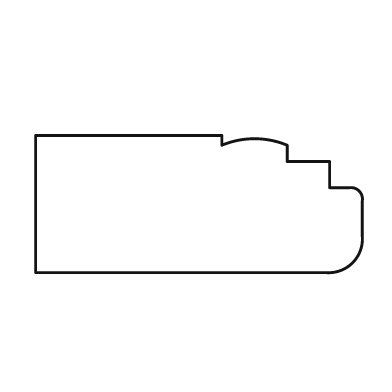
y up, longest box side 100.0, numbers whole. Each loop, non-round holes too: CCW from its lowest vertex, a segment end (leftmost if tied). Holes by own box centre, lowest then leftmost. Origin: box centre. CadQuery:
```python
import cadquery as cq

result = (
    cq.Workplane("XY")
    .moveTo(-50.0, -21.0)
    .lineTo(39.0, -21.0)
    .threePointArc((47.0, -18.0), (50.0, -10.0))
    .lineTo(50.0, 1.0)
    .threePointArc((49.0, 4.0), (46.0, 5.0))
    .lineTo(40.0, 5.0)
    .lineTo(40.0, 13.0)
    .lineTo(27.0, 13.0)
    .lineTo(27.0, 18.0)
    .threePointArc((17.0, 20.0), (7.0, 18.0))
    .lineTo(7.0, 21.0)
    .lineTo(-50.0, 21.0)
    .close()
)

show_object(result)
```